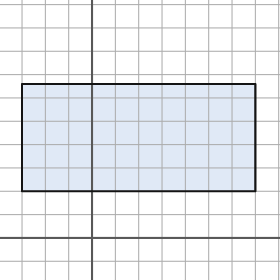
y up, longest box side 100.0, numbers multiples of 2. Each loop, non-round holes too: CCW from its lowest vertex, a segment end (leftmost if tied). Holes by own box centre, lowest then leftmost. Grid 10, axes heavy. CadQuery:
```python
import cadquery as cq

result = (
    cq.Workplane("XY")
    .moveTo(-30.0, 20.0)
    .lineTo(70.0, 20.0)
    .lineTo(70.0, 66.0)
    .lineTo(-30.0, 66.0)
    .close()
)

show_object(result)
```